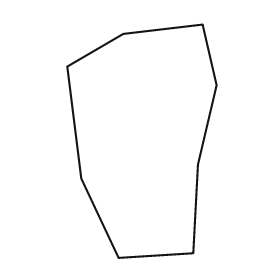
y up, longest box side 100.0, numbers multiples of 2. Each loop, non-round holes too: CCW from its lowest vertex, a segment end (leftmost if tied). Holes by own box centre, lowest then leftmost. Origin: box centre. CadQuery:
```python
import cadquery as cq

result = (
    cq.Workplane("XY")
    .moveTo(-10.0, -50.0)
    .lineTo(22.0, -48.0)
    .lineTo(24.0, -10.0)
    .lineTo(32.0, 24.0)
    .lineTo(26.0, 50.0)
    .lineTo(-8.0, 46.0)
    .lineTo(-32.0, 32.0)
    .lineTo(-26.0, -16.0)
    .close()
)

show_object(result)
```